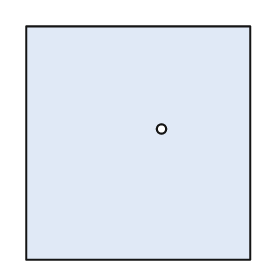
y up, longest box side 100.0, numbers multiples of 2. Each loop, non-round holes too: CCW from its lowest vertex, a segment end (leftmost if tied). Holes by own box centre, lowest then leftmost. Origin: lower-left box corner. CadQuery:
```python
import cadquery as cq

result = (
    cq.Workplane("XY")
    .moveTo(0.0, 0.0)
    .lineTo(96.0, 0.0)
    .lineTo(96.0, 100.0)
    .lineTo(0.0, 100.0)
    .close()
    .moveTo(58.0, 56.0)
    .circle(2.0)
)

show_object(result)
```